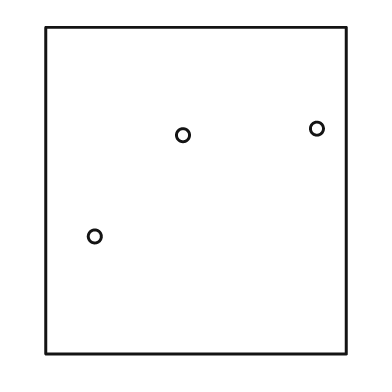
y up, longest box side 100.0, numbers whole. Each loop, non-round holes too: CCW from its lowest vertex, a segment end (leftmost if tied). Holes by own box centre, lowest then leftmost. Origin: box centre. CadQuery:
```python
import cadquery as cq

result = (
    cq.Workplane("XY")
    .moveTo(-46.0, -50.0)
    .lineTo(46.0, -50.0)
    .lineTo(46.0, 50.0)
    .lineTo(-46.0, 50.0)
    .close()
    .moveTo(-31.0, -14.0)
    .circle(2.0)
    .moveTo(-4.0, 17.0)
    .circle(2.0)
    .moveTo(37.0, 19.0)
    .circle(2.0)
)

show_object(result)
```